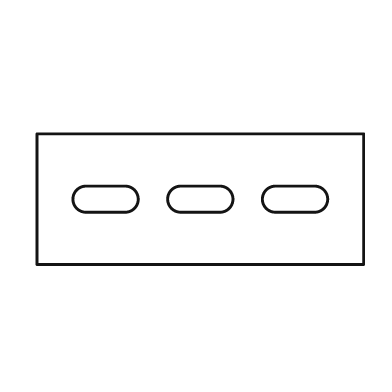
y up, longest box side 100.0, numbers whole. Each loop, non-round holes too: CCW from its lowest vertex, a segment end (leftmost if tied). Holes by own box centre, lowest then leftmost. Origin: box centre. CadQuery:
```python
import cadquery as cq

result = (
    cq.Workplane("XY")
    .moveTo(-50.0, -20.0)
    .lineTo(50.0, -20.0)
    .lineTo(50.0, 20.0)
    .lineTo(-50.0, 20.0)
    .close()
    .moveTo(-35.0, -4.0)
    .lineTo(-23.0, -4.0)
    .threePointArc((-19.0, 0.0), (-23.0, 4.0))
    .lineTo(-35.0, 4.0)
    .threePointArc((-39.0, 0.0), (-35.0, -4.0))
    .close()
    .moveTo(-6.0, -4.0)
    .lineTo(6.0, -4.0)
    .threePointArc((10.0, 0.0), (6.0, 4.0))
    .lineTo(-6.0, 4.0)
    .threePointArc((-10.0, 0.0), (-6.0, -4.0))
    .close()
    .moveTo(23.0, -4.0)
    .lineTo(35.0, -4.0)
    .threePointArc((39.0, 0.0), (35.0, 4.0))
    .lineTo(23.0, 4.0)
    .threePointArc((19.0, 0.0), (23.0, -4.0))
    .close()
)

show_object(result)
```